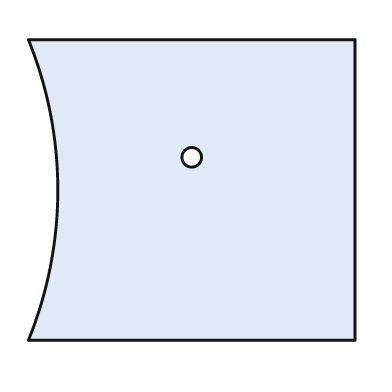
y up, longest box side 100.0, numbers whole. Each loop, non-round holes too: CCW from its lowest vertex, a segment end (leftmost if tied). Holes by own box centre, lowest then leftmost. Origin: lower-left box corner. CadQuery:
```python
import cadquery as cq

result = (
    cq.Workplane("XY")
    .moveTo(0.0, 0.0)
    .lineTo(100.0, 0.0)
    .lineTo(100.0, 92.0)
    .lineTo(0.0, 92.0)
    .threePointArc((9.0, 46.0), (0.0, 0.0))
    .close()
    .moveTo(50.0, 56.0)
    .circle(3.0)
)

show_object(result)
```